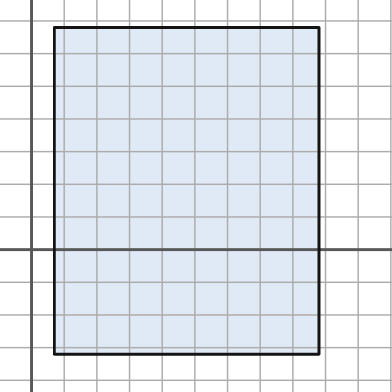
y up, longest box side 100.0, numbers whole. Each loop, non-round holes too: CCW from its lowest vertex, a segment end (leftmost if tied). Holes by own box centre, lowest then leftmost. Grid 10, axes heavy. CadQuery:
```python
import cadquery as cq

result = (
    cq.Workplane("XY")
    .moveTo(7.0, -32.0)
    .lineTo(88.0, -32.0)
    .lineTo(88.0, 68.0)
    .lineTo(7.0, 68.0)
    .close()
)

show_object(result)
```